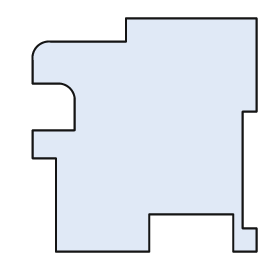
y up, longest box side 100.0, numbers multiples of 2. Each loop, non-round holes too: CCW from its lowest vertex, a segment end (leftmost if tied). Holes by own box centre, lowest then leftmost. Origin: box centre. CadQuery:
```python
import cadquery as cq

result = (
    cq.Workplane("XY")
    .moveTo(-38.0, -50.0)
    .lineTo(2.0, -50.0)
    .lineTo(2.0, -34.0)
    .lineTo(38.0, -34.0)
    .lineTo(38.0, -50.0)
    .lineTo(48.0, -50.0)
    .lineTo(48.0, -40.0)
    .lineTo(42.0, -40.0)
    .lineTo(42.0, 10.0)
    .lineTo(48.0, 10.0)
    .lineTo(48.0, 50.0)
    .lineTo(-8.0, 50.0)
    .lineTo(-8.0, 40.0)
    .lineTo(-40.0, 40.0)
    .threePointArc((-46.0, 38.0), (-48.0, 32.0))
    .lineTo(-48.0, 22.0)
    .lineTo(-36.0, 22.0)
    .threePointArc((-32.0, 20.0), (-30.0, 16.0))
    .lineTo(-30.0, 2.0)
    .lineTo(-48.0, 2.0)
    .lineTo(-48.0, -10.0)
    .lineTo(-38.0, -10.0)
    .close()
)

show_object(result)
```